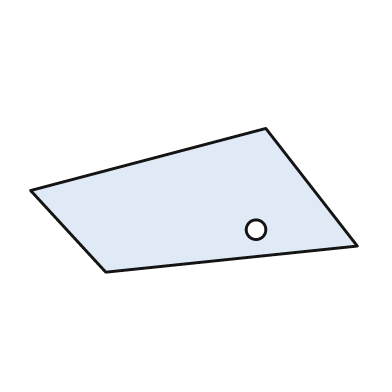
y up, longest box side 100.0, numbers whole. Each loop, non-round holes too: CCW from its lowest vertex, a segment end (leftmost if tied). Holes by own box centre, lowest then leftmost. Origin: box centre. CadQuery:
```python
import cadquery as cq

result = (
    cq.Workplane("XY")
    .moveTo(-27.0, -22.0)
    .lineTo(50.0, -14.0)
    .lineTo(22.0, 22.0)
    .lineTo(-50.0, 3.0)
    .close()
    .moveTo(19.0, -9.0)
    .circle(3.0)
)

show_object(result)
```